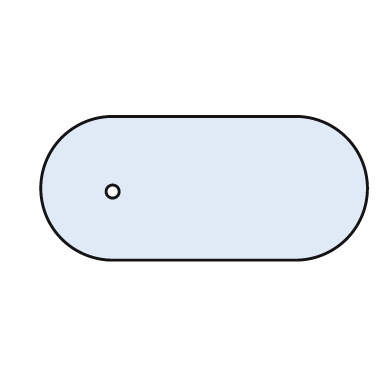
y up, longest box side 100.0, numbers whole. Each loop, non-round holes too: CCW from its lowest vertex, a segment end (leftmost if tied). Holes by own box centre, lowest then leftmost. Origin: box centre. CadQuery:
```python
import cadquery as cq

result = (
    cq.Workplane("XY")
    .moveTo(-28.0, -22.0)
    .lineTo(28.0, -22.0)
    .threePointArc((50.0, 0.0), (28.0, 22.0))
    .lineTo(-28.0, 22.0)
    .threePointArc((-50.0, 0.0), (-28.0, -22.0))
    .close()
    .moveTo(-28.0, -1.0)
    .circle(2.0)
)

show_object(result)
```